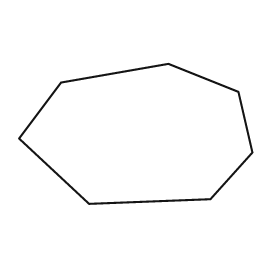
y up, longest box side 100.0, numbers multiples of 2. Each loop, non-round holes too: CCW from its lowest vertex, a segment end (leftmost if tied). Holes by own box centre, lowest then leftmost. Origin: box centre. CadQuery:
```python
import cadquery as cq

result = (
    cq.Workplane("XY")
    .moveTo(-20.0, -30.0)
    .lineTo(32.0, -28.0)
    .lineTo(50.0, -8.0)
    .lineTo(44.0, 18.0)
    .lineTo(14.0, 30.0)
    .lineTo(-32.0, 22.0)
    .lineTo(-50.0, -2.0)
    .close()
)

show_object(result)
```